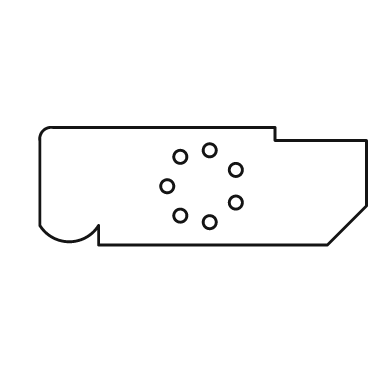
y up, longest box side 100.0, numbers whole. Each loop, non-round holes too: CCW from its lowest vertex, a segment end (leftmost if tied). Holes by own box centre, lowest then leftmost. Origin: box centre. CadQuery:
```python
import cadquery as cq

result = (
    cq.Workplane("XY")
    .moveTo(-32.0, -18.0)
    .lineTo(38.0, -18.0)
    .lineTo(50.0, -6.0)
    .lineTo(50.0, 14.0)
    .lineTo(22.0, 14.0)
    .lineTo(22.0, 18.0)
    .lineTo(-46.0, 18.0)
    .threePointArc((-49.0, 17.0), (-50.0, 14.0))
    .lineTo(-50.0, -12.0)
    .threePointArc((-41.0, -17.0), (-32.0, -12.0))
    .close()
    .moveTo(2.0, -11.0)
    .circle(2.0)
    .moveTo(-7.0, -9.0)
    .circle(2.0)
    .moveTo(10.0, -5.0)
    .circle(2.0)
    .moveTo(-11.0, 0.0)
    .circle(2.0)
    .moveTo(10.0, 5.0)
    .circle(2.0)
    .moveTo(-7.0, 9.0)
    .circle(2.0)
    .moveTo(2.0, 11.0)
    .circle(2.0)
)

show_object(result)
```